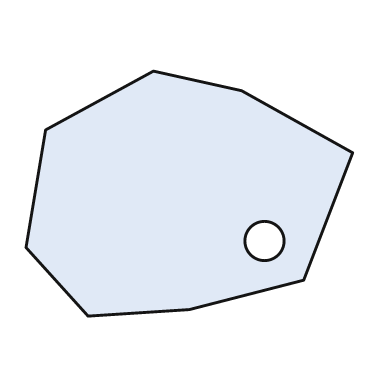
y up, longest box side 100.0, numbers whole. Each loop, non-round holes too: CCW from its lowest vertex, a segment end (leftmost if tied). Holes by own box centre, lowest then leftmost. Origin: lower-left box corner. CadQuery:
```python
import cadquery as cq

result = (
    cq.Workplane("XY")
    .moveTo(19.0, 0.0)
    .lineTo(50.0, 2.0)
    .lineTo(85.0, 11.0)
    .lineTo(100.0, 50.0)
    .lineTo(66.0, 69.0)
    .lineTo(39.0, 75.0)
    .lineTo(6.0, 57.0)
    .lineTo(0.0, 21.0)
    .close()
    .moveTo(73.0, 23.0)
    .circle(6.0)
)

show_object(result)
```